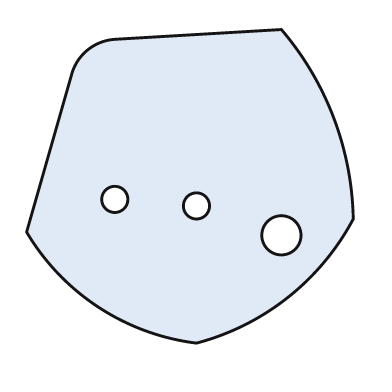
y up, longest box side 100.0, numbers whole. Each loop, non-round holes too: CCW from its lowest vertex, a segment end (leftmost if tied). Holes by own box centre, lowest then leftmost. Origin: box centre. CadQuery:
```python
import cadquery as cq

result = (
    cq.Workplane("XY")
    .moveTo(2.0, -48.0)
    .threePointArc((30.0, -34.0), (50.0, -10.0))
    .threePointArc((44.0, 21.0), (28.0, 48.0))
    .lineTo(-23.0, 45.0)
    .threePointArc((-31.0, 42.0), (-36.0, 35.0))
    .lineTo(-50.0, -14.0)
    .threePointArc((-28.0, -37.0), (2.0, -48.0))
    .close()
    .moveTo(28.0, -15.0)
    .circle(6.0)
    .moveTo(2.0, -6.0)
    .circle(4.0)
    .moveTo(-23.0, -4.0)
    .circle(4.0)
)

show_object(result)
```